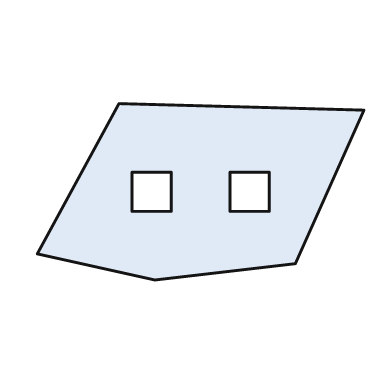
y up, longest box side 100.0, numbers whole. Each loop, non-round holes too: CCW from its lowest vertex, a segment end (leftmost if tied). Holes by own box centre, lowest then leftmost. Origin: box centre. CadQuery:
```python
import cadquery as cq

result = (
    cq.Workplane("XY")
    .moveTo(-14.0, -27.0)
    .lineTo(29.0, -22.0)
    .lineTo(50.0, 25.0)
    .lineTo(-25.0, 27.0)
    .lineTo(-50.0, -19.0)
    .close()
    .moveTo(-21.0, -6.0)
    .lineTo(-9.0, -6.0)
    .lineTo(-9.0, 6.0)
    .lineTo(-21.0, 6.0)
    .close()
    .moveTo(9.0, -6.0)
    .lineTo(21.0, -6.0)
    .lineTo(21.0, 6.0)
    .lineTo(9.0, 6.0)
    .close()
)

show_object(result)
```